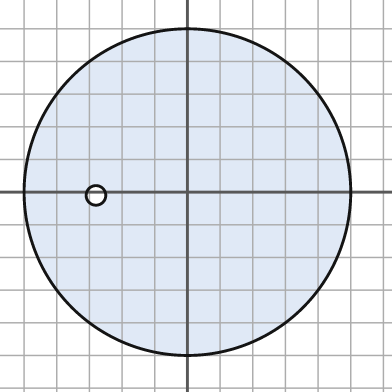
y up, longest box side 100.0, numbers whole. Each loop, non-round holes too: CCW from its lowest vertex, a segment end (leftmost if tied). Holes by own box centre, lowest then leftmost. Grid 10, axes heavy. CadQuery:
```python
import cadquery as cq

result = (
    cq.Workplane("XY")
    .moveTo(0.0, 0.0)
    .circle(50.0)
    .moveTo(-28.0, -1.0)
    .circle(3.0)
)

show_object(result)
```